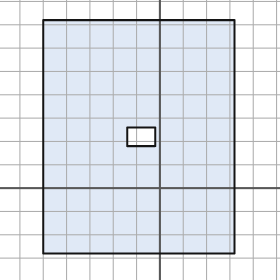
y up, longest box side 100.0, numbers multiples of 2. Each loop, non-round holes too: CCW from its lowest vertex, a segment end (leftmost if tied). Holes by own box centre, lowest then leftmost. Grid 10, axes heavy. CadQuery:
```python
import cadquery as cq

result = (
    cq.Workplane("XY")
    .moveTo(-50.0, -28.0)
    .lineTo(32.0, -28.0)
    .lineTo(32.0, 72.0)
    .lineTo(-50.0, 72.0)
    .close()
    .moveTo(-14.0, 18.0)
    .lineTo(-2.0, 18.0)
    .lineTo(-2.0, 26.0)
    .lineTo(-14.0, 26.0)
    .close()
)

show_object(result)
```